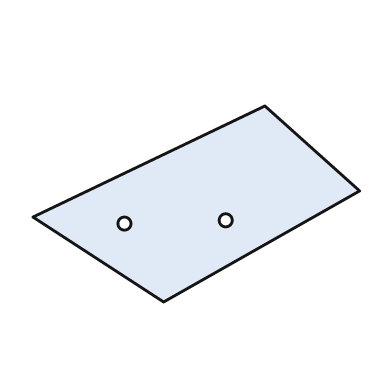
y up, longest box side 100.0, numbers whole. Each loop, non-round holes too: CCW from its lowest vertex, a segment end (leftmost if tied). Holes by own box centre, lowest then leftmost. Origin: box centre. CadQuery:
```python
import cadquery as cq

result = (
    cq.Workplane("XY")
    .moveTo(-10.0, -30.0)
    .lineTo(50.0, 4.0)
    .lineTo(21.0, 30.0)
    .lineTo(-50.0, -4.0)
    .close()
    .moveTo(-22.0, -6.0)
    .circle(2.0)
    .moveTo(9.0, -5.0)
    .circle(2.0)
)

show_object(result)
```